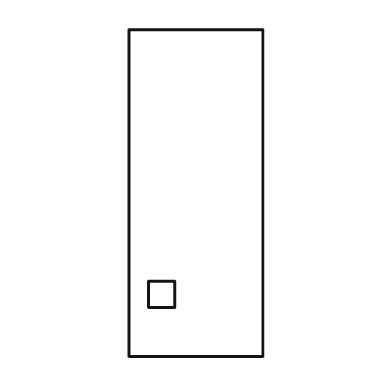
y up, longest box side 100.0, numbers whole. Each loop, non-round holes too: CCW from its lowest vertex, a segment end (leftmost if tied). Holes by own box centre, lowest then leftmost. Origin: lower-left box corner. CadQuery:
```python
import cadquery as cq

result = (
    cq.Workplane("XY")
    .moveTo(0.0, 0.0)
    .lineTo(41.0, 0.0)
    .lineTo(41.0, 100.0)
    .lineTo(0.0, 100.0)
    .close()
    .moveTo(6.0, 15.0)
    .lineTo(14.0, 15.0)
    .lineTo(14.0, 23.0)
    .lineTo(6.0, 23.0)
    .close()
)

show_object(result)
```